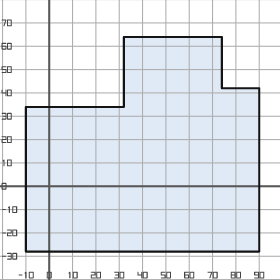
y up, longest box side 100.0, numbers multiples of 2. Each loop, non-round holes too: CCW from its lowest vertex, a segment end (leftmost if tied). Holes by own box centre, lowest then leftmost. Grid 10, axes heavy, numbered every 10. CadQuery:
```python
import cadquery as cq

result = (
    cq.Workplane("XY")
    .moveTo(-10.0, -28.0)
    .lineTo(90.0, -28.0)
    .lineTo(90.0, 42.0)
    .lineTo(74.0, 42.0)
    .lineTo(74.0, 64.0)
    .lineTo(32.0, 64.0)
    .lineTo(32.0, 34.0)
    .lineTo(-10.0, 34.0)
    .close()
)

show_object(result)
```